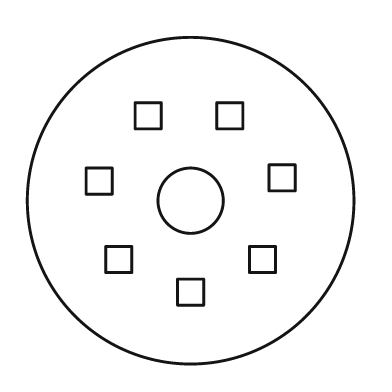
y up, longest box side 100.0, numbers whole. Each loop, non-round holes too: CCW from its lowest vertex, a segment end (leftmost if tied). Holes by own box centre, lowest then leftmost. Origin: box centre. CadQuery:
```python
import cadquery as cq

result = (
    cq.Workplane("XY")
    .moveTo(0.0, 0.0)
    .circle(50.0)
    .moveTo(-4.0, -32.0)
    .lineTo(4.0, -32.0)
    .lineTo(4.0, -24.0)
    .lineTo(-4.0, -24.0)
    .close()
    .moveTo(-26.0, -22.0)
    .lineTo(-18.0, -22.0)
    .lineTo(-18.0, -14.0)
    .lineTo(-26.0, -14.0)
    .close()
    .moveTo(18.0, -22.0)
    .lineTo(26.0, -22.0)
    .lineTo(26.0, -14.0)
    .lineTo(18.0, -14.0)
    .close()
    .moveTo(0.0, 0.0)
    .circle(10.0)
    .moveTo(-32.0, 2.0)
    .lineTo(-24.0, 2.0)
    .lineTo(-24.0, 10.0)
    .lineTo(-32.0, 10.0)
    .close()
    .moveTo(24.0, 3.0)
    .lineTo(32.0, 3.0)
    .lineTo(32.0, 11.0)
    .lineTo(24.0, 11.0)
    .close()
    .moveTo(-17.0, 22.0)
    .lineTo(-9.0, 22.0)
    .lineTo(-9.0, 30.0)
    .lineTo(-17.0, 30.0)
    .close()
    .moveTo(8.0, 22.0)
    .lineTo(16.0, 22.0)
    .lineTo(16.0, 30.0)
    .lineTo(8.0, 30.0)
    .close()
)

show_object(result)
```